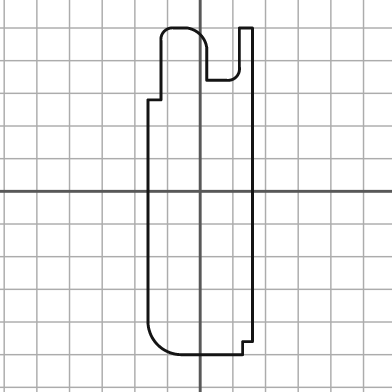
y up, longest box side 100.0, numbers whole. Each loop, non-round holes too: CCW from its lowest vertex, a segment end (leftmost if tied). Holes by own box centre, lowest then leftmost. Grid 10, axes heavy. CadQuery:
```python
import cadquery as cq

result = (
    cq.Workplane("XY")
    .moveTo(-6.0, -50.0)
    .lineTo(13.0, -50.0)
    .lineTo(13.0, -46.0)
    .lineTo(16.0, -46.0)
    .lineTo(16.0, 50.0)
    .lineTo(12.0, 50.0)
    .lineTo(12.0, 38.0)
    .threePointArc((11.0, 35.0), (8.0, 34.0))
    .lineTo(2.0, 34.0)
    .lineTo(2.0, 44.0)
    .threePointArc((0.0, 48.0), (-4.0, 50.0))
    .lineTo(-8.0, 50.0)
    .threePointArc((-11.0, 49.0), (-12.0, 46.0))
    .lineTo(-12.0, 28.0)
    .lineTo(-16.0, 28.0)
    .lineTo(-16.0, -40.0)
    .threePointArc((-13.0, -47.0), (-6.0, -50.0))
    .close()
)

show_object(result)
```